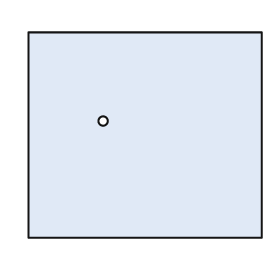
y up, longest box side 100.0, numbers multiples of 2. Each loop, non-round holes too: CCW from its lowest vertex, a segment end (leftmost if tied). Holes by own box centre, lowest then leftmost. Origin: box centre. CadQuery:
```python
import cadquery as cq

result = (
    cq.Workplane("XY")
    .moveTo(-50.0, -44.0)
    .lineTo(50.0, -44.0)
    .lineTo(50.0, 44.0)
    .lineTo(-50.0, 44.0)
    .close()
    .moveTo(-18.0, 6.0)
    .circle(2.0)
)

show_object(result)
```